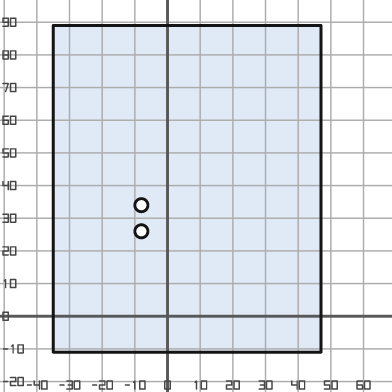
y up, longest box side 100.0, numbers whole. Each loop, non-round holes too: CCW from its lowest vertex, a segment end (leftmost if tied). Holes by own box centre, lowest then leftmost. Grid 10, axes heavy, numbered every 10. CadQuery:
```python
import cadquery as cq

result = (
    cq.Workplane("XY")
    .moveTo(-35.0, -11.0)
    .lineTo(47.0, -11.0)
    .lineTo(47.0, 89.0)
    .lineTo(-35.0, 89.0)
    .close()
    .moveTo(-8.0, 26.0)
    .circle(2.0)
    .moveTo(-8.0, 34.0)
    .circle(2.0)
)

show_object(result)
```